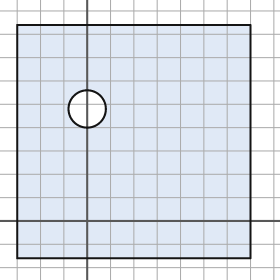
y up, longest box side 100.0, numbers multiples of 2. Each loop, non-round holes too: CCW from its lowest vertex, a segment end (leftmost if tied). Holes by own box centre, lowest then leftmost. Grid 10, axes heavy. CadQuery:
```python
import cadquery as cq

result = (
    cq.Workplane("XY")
    .moveTo(-30.0, -16.0)
    .lineTo(70.0, -16.0)
    .lineTo(70.0, 84.0)
    .lineTo(-30.0, 84.0)
    .close()
    .moveTo(0.0, 48.0)
    .circle(8.0)
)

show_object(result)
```